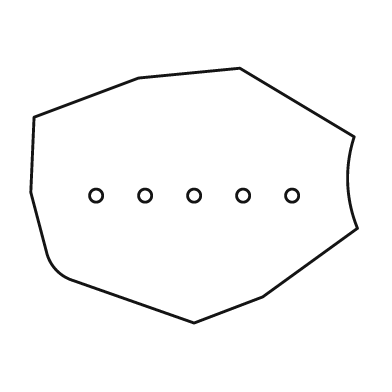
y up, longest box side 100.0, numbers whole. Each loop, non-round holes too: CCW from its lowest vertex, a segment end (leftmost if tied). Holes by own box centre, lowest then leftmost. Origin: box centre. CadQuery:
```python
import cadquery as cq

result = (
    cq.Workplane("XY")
    .moveTo(0.0, -39.0)
    .lineTo(21.0, -31.0)
    .lineTo(50.0, -10.0)
    .threePointArc((47.0, 4.0), (49.0, 18.0))
    .lineTo(14.0, 39.0)
    .lineTo(-17.0, 36.0)
    .lineTo(-49.0, 24.0)
    .lineTo(-50.0, 1.0)
    .lineTo(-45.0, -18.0)
    .threePointArc((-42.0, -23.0), (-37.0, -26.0))
    .close()
    .moveTo(-30.0, 0.0)
    .circle(2.0)
    .moveTo(-15.0, 0.0)
    .circle(2.0)
    .moveTo(0.0, 0.0)
    .circle(2.0)
    .moveTo(15.0, 0.0)
    .circle(2.0)
    .moveTo(30.0, 0.0)
    .circle(2.0)
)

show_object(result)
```